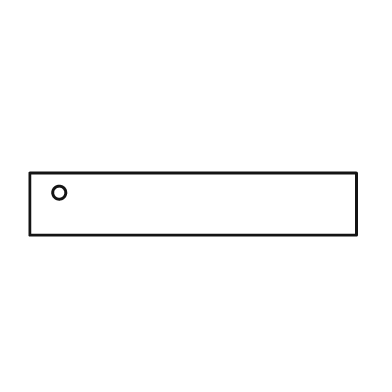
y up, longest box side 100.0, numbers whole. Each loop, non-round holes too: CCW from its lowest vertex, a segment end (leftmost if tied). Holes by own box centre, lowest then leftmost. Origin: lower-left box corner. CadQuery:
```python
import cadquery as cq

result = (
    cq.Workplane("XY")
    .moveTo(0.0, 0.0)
    .lineTo(100.0, 0.0)
    .lineTo(100.0, 19.0)
    .lineTo(0.0, 19.0)
    .close()
    .moveTo(9.0, 13.0)
    .circle(2.0)
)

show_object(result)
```